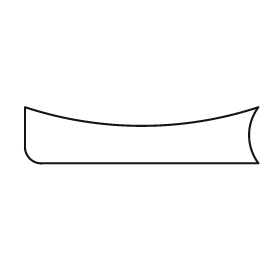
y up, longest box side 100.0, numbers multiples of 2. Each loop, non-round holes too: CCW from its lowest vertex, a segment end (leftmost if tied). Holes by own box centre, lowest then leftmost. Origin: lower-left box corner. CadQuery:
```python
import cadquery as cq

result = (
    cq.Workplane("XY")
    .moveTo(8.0, 0.0)
    .lineTo(100.0, 0.0)
    .threePointArc((96.0, 12.0), (100.0, 24.0))
    .threePointArc((50.0, 16.0), (0.0, 24.0))
    .lineTo(0.0, 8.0)
    .threePointArc((2.0, 2.0), (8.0, 0.0))
    .close()
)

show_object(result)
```